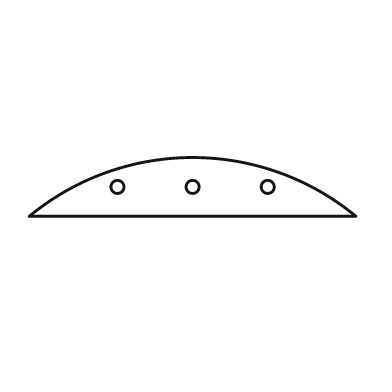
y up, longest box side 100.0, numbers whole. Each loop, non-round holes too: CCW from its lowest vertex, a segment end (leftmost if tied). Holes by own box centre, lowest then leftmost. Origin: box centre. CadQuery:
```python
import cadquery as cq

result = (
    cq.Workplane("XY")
    .moveTo(-50.0, -9.0)
    .lineTo(50.0, -9.0)
    .threePointArc((0.0, 9.0), (-50.0, -9.0))
    .close()
    .moveTo(-23.0, 0.0)
    .circle(2.0)
    .moveTo(0.0, 0.0)
    .circle(2.0)
    .moveTo(23.0, 0.0)
    .circle(2.0)
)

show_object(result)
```